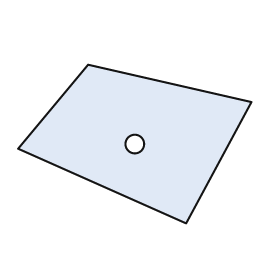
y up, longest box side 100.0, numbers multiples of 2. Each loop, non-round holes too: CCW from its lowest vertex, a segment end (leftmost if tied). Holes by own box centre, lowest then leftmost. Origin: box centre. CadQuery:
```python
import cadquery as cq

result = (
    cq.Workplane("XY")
    .moveTo(22.0, -34.0)
    .lineTo(50.0, 18.0)
    .lineTo(-20.0, 34.0)
    .lineTo(-50.0, -2.0)
    .close()
    .moveTo(0.0, 0.0)
    .circle(4.0)
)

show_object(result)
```